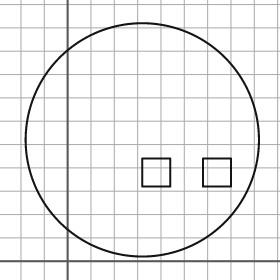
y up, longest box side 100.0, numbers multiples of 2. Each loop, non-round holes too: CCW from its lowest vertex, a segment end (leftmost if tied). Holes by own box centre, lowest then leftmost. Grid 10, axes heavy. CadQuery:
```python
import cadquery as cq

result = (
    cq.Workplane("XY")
    .moveTo(32.0, 52.0)
    .circle(50.0)
    .moveTo(32.0, 32.0)
    .lineTo(44.0, 32.0)
    .lineTo(44.0, 44.0)
    .lineTo(32.0, 44.0)
    .close()
    .moveTo(58.0, 32.0)
    .lineTo(70.0, 32.0)
    .lineTo(70.0, 44.0)
    .lineTo(58.0, 44.0)
    .close()
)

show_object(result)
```